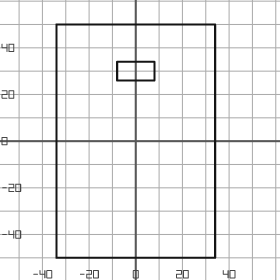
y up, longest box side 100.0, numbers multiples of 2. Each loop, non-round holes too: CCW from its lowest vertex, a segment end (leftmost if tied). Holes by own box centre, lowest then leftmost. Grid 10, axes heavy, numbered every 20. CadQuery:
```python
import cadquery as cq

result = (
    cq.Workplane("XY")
    .moveTo(-34.0, -50.0)
    .lineTo(34.0, -50.0)
    .lineTo(34.0, 50.0)
    .lineTo(-34.0, 50.0)
    .close()
    .moveTo(-8.0, 26.0)
    .lineTo(8.0, 26.0)
    .lineTo(8.0, 34.0)
    .lineTo(-8.0, 34.0)
    .close()
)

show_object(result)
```